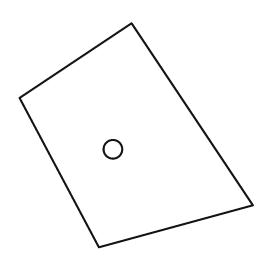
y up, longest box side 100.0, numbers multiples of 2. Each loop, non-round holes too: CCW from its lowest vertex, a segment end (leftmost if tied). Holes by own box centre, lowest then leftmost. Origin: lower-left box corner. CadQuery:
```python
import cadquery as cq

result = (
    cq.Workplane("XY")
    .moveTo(34.0, 0.0)
    .lineTo(100.0, 18.0)
    .lineTo(48.0, 96.0)
    .lineTo(0.0, 64.0)
    .close()
    .moveTo(40.0, 42.0)
    .circle(4.0)
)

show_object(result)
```